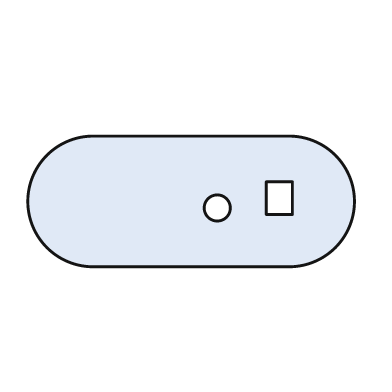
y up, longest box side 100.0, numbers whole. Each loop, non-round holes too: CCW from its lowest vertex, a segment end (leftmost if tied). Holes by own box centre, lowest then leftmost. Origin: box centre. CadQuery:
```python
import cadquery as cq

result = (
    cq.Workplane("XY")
    .moveTo(-30.0, -20.0)
    .lineTo(30.0, -20.0)
    .threePointArc((50.0, 0.0), (30.0, 20.0))
    .lineTo(-30.0, 20.0)
    .threePointArc((-50.0, 0.0), (-30.0, -20.0))
    .close()
    .moveTo(8.0, -2.0)
    .circle(4.0)
    .moveTo(23.0, -4.0)
    .lineTo(31.0, -4.0)
    .lineTo(31.0, 6.0)
    .lineTo(23.0, 6.0)
    .close()
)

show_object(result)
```